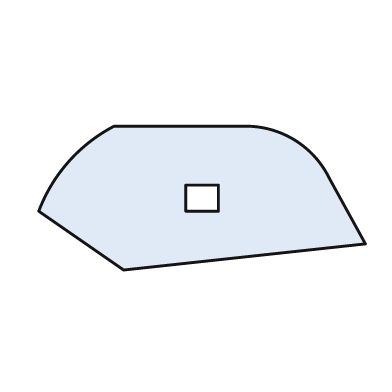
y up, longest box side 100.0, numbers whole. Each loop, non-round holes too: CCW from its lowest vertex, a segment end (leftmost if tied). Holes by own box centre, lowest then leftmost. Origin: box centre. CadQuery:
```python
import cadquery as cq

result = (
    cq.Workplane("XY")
    .moveTo(-24.0, -22.0)
    .lineTo(50.0, -14.0)
    .lineTo(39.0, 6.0)
    .threePointArc((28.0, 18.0), (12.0, 22.0))
    .lineTo(-27.0, 22.0)
    .threePointArc((-41.0, 11.0), (-50.0, -4.0))
    .close()
    .moveTo(-5.0, -4.0)
    .lineTo(5.0, -4.0)
    .lineTo(5.0, 4.0)
    .lineTo(-5.0, 4.0)
    .close()
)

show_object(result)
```